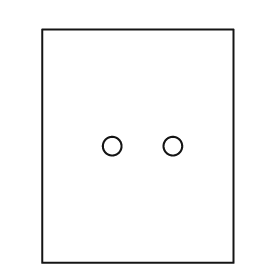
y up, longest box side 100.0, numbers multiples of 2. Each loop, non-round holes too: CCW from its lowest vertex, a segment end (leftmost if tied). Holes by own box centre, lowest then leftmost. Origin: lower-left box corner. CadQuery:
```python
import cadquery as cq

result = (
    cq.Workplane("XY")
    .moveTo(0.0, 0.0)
    .lineTo(82.0, 0.0)
    .lineTo(82.0, 100.0)
    .lineTo(0.0, 100.0)
    .close()
    .moveTo(30.0, 50.0)
    .circle(4.0)
    .moveTo(56.0, 50.0)
    .circle(4.0)
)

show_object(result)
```